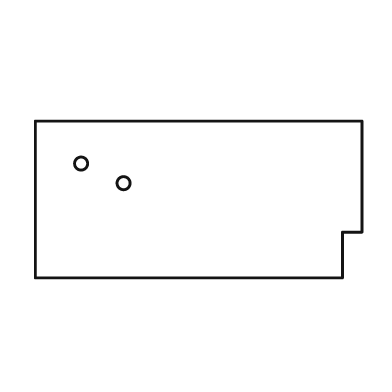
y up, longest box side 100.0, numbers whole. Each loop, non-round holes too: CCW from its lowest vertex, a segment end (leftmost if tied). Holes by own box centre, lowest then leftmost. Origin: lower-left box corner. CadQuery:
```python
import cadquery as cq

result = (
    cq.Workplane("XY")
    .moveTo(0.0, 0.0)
    .lineTo(94.0, 0.0)
    .lineTo(94.0, 14.0)
    .lineTo(100.0, 14.0)
    .lineTo(100.0, 48.0)
    .lineTo(0.0, 48.0)
    .close()
    .moveTo(27.0, 29.0)
    .circle(2.0)
    .moveTo(14.0, 35.0)
    .circle(2.0)
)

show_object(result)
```